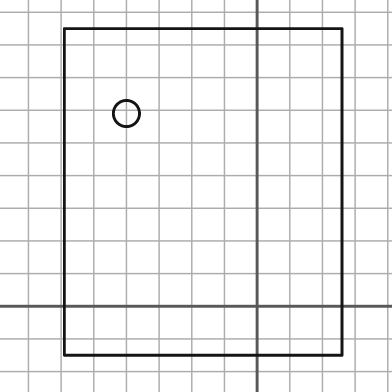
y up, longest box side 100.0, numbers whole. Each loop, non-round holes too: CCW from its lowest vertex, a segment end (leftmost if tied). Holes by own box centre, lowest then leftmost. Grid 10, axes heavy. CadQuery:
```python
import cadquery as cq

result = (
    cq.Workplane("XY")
    .moveTo(-59.0, -15.0)
    .lineTo(26.0, -15.0)
    .lineTo(26.0, 85.0)
    .lineTo(-59.0, 85.0)
    .close()
    .moveTo(-40.0, 59.0)
    .circle(4.0)
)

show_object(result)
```